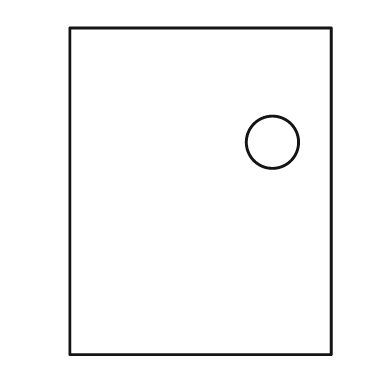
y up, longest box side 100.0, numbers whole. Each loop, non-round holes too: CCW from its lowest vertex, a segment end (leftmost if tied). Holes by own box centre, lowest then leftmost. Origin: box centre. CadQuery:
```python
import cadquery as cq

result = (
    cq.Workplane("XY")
    .moveTo(-40.0, -50.0)
    .lineTo(40.0, -50.0)
    .lineTo(40.0, 50.0)
    .lineTo(-40.0, 50.0)
    .close()
    .moveTo(22.0, 15.0)
    .circle(8.0)
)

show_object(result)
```